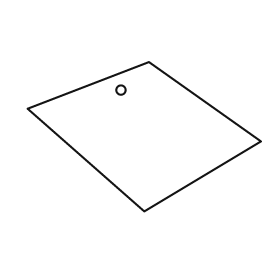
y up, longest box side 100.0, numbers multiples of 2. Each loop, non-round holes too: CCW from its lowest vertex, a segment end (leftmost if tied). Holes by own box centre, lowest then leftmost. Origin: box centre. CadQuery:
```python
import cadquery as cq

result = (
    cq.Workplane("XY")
    .moveTo(0.0, -32.0)
    .lineTo(50.0, -2.0)
    .lineTo(2.0, 32.0)
    .lineTo(-50.0, 12.0)
    .close()
    .moveTo(-10.0, 20.0)
    .circle(2.0)
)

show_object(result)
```